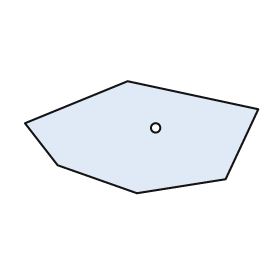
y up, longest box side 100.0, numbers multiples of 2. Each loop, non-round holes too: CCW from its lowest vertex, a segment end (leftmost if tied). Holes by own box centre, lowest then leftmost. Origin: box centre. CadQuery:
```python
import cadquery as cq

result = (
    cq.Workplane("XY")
    .moveTo(-2.0, -24.0)
    .lineTo(36.0, -18.0)
    .lineTo(50.0, 12.0)
    .lineTo(-6.0, 24.0)
    .lineTo(-50.0, 6.0)
    .lineTo(-36.0, -12.0)
    .close()
    .moveTo(6.0, 4.0)
    .circle(2.0)
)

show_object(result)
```